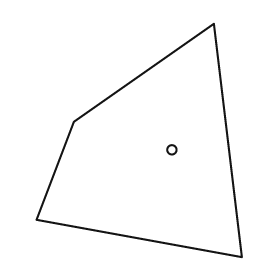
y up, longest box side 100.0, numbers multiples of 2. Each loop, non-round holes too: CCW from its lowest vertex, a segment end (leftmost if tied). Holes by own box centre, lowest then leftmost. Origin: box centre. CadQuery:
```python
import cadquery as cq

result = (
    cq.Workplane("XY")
    .moveTo(44.0, -50.0)
    .lineTo(32.0, 50.0)
    .lineTo(-28.0, 8.0)
    .lineTo(-44.0, -34.0)
    .close()
    .moveTo(14.0, -4.0)
    .circle(2.0)
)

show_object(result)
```